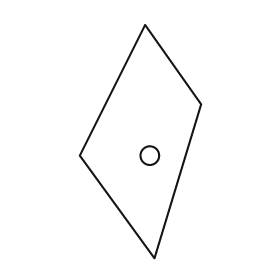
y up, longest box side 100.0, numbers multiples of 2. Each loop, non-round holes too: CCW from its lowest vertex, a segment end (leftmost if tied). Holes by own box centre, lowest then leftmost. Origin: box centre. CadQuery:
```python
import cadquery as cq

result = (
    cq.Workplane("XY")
    .moveTo(6.0, -50.0)
    .lineTo(26.0, 16.0)
    .lineTo(2.0, 50.0)
    .lineTo(-26.0, -6.0)
    .close()
    .moveTo(4.0, -6.0)
    .circle(4.0)
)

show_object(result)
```